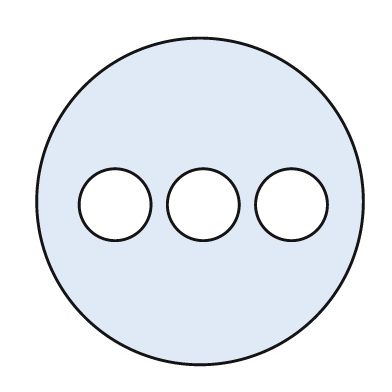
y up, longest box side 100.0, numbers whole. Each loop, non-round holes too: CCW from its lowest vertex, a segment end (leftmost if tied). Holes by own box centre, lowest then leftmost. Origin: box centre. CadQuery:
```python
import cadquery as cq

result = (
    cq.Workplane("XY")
    .moveTo(0.0, 0.0)
    .circle(50.0)
    .moveTo(-26.0, -1.0)
    .circle(11.0)
    .moveTo(1.0, -1.0)
    .circle(11.0)
    .moveTo(28.0, -1.0)
    .circle(11.0)
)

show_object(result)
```